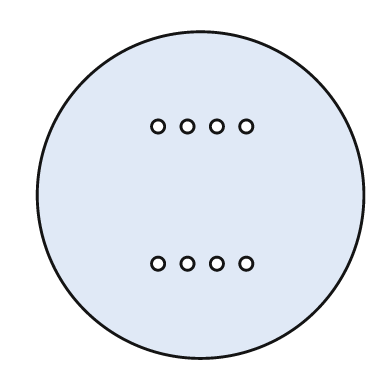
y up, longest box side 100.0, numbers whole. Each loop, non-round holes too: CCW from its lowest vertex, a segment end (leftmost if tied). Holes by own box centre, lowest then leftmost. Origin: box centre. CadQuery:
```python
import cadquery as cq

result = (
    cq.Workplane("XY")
    .moveTo(0.0, 0.0)
    .circle(50.0)
    .moveTo(-13.0, -21.0)
    .circle(2.0)
    .moveTo(-4.0, -21.0)
    .circle(2.0)
    .moveTo(5.0, -21.0)
    .circle(2.0)
    .moveTo(14.0, -21.0)
    .circle(2.0)
    .moveTo(-13.0, 21.0)
    .circle(2.0)
    .moveTo(-4.0, 21.0)
    .circle(2.0)
    .moveTo(5.0, 21.0)
    .circle(2.0)
    .moveTo(14.0, 21.0)
    .circle(2.0)
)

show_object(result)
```